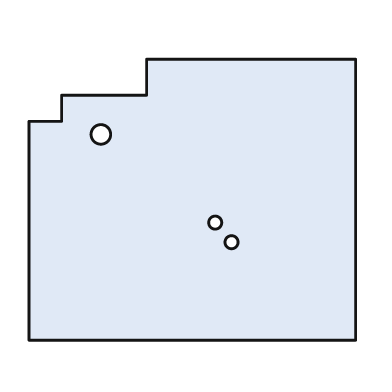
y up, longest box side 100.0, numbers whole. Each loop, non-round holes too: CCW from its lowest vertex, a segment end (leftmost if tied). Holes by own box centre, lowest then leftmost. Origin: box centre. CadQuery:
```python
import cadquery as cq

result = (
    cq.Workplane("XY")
    .moveTo(-50.0, -43.0)
    .lineTo(50.0, -43.0)
    .lineTo(50.0, 43.0)
    .lineTo(-14.0, 43.0)
    .lineTo(-14.0, 32.0)
    .lineTo(-40.0, 32.0)
    .lineTo(-40.0, 24.0)
    .lineTo(-50.0, 24.0)
    .close()
    .moveTo(12.0, -13.0)
    .circle(2.0)
    .moveTo(7.0, -7.0)
    .circle(2.0)
    .moveTo(-28.0, 20.0)
    .circle(3.0)
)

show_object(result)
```